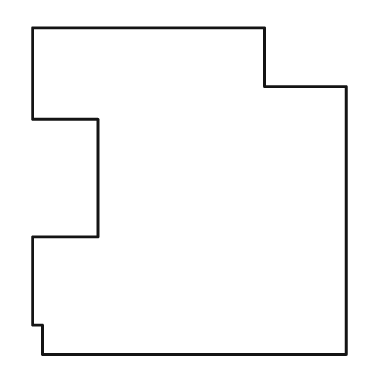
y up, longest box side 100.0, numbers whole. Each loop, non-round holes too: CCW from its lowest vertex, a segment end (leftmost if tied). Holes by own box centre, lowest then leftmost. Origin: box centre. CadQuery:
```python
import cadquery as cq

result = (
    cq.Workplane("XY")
    .moveTo(-45.0, -50.0)
    .lineTo(48.0, -50.0)
    .lineTo(48.0, 32.0)
    .lineTo(23.0, 32.0)
    .lineTo(23.0, 50.0)
    .lineTo(-48.0, 50.0)
    .lineTo(-48.0, 22.0)
    .lineTo(-28.0, 22.0)
    .lineTo(-28.0, -14.0)
    .lineTo(-48.0, -14.0)
    .lineTo(-48.0, -41.0)
    .lineTo(-45.0, -41.0)
    .close()
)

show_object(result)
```